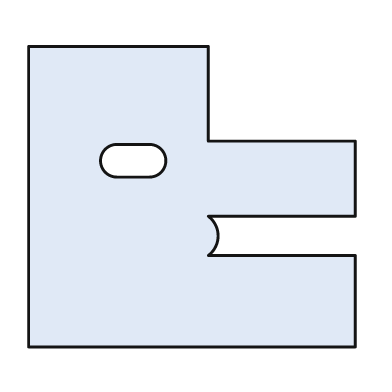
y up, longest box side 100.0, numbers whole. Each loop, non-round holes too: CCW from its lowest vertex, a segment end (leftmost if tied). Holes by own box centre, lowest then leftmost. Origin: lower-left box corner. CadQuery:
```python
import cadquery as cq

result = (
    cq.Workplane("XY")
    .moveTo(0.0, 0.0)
    .lineTo(100.0, 0.0)
    .lineTo(100.0, 28.0)
    .lineTo(55.0, 28.0)
    .threePointArc((58.0, 34.0), (55.0, 40.0))
    .lineTo(100.0, 40.0)
    .lineTo(100.0, 63.0)
    .lineTo(55.0, 63.0)
    .lineTo(55.0, 92.0)
    .lineTo(0.0, 92.0)
    .close()
    .moveTo(27.0, 52.0)
    .lineTo(37.0, 52.0)
    .threePointArc((42.0, 57.0), (37.0, 62.0))
    .lineTo(27.0, 62.0)
    .threePointArc((22.0, 57.0), (27.0, 52.0))
    .close()
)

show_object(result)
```